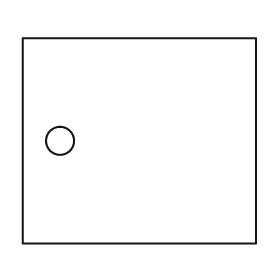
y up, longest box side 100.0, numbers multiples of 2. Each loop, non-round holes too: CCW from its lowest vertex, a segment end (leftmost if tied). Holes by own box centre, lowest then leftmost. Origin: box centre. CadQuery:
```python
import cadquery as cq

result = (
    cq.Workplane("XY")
    .moveTo(-50.0, -44.0)
    .lineTo(50.0, -44.0)
    .lineTo(50.0, 44.0)
    .lineTo(-50.0, 44.0)
    .close()
    .moveTo(-34.0, 0.0)
    .circle(6.0)
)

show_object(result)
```